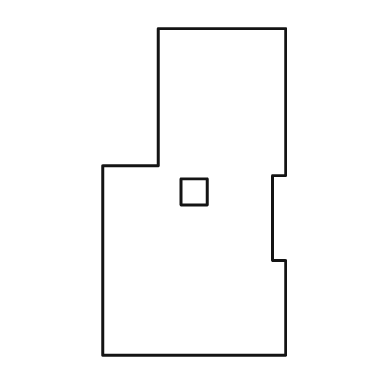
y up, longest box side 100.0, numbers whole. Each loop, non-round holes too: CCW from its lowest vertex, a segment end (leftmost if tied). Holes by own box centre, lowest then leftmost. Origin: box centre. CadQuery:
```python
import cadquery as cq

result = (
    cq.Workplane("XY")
    .moveTo(-28.0, -50.0)
    .lineTo(28.0, -50.0)
    .lineTo(28.0, -21.0)
    .lineTo(24.0, -21.0)
    .lineTo(24.0, 5.0)
    .lineTo(28.0, 5.0)
    .lineTo(28.0, 50.0)
    .lineTo(-11.0, 50.0)
    .lineTo(-11.0, 8.0)
    .lineTo(-28.0, 8.0)
    .close()
    .moveTo(-4.0, -4.0)
    .lineTo(4.0, -4.0)
    .lineTo(4.0, 4.0)
    .lineTo(-4.0, 4.0)
    .close()
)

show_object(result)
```